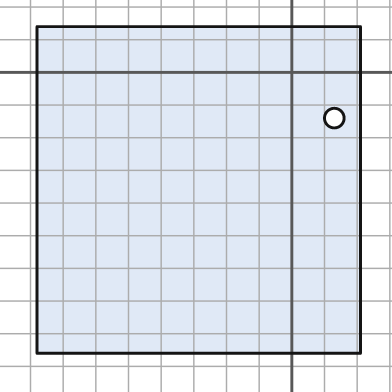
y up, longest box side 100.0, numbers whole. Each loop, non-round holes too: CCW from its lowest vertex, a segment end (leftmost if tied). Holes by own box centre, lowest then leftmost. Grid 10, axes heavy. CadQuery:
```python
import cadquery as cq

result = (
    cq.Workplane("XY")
    .moveTo(-78.0, -86.0)
    .lineTo(21.0, -86.0)
    .lineTo(21.0, 14.0)
    .lineTo(-78.0, 14.0)
    .close()
    .moveTo(13.0, -14.0)
    .circle(3.0)
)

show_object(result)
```